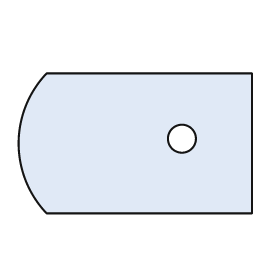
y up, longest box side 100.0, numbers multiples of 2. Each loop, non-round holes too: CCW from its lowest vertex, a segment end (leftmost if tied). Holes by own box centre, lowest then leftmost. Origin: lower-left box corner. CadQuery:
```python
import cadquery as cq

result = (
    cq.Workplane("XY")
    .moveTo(12.0, 0.0)
    .lineTo(100.0, 0.0)
    .lineTo(100.0, 60.0)
    .lineTo(12.0, 60.0)
    .threePointArc((0.0, 30.0), (12.0, 0.0))
    .close()
    .moveTo(70.0, 32.0)
    .circle(6.0)
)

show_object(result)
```